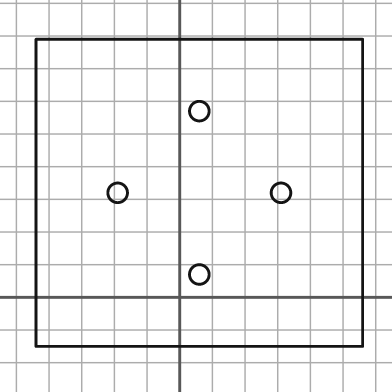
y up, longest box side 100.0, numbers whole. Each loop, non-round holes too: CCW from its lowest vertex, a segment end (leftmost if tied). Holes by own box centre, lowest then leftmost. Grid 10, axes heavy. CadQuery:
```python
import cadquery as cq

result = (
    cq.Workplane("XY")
    .moveTo(-44.0, -15.0)
    .lineTo(56.0, -15.0)
    .lineTo(56.0, 79.0)
    .lineTo(-44.0, 79.0)
    .close()
    .moveTo(6.0, 7.0)
    .circle(3.0)
    .moveTo(-19.0, 32.0)
    .circle(3.0)
    .moveTo(31.0, 32.0)
    .circle(3.0)
    .moveTo(6.0, 57.0)
    .circle(3.0)
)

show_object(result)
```